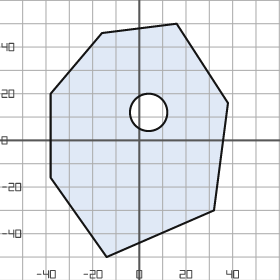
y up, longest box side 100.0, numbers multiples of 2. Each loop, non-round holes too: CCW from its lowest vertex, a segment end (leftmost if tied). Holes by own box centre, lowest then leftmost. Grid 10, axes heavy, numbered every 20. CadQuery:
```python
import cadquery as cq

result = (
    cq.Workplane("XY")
    .moveTo(-14.0, -50.0)
    .lineTo(32.0, -30.0)
    .lineTo(38.0, 16.0)
    .lineTo(16.0, 50.0)
    .lineTo(-16.0, 46.0)
    .lineTo(-38.0, 20.0)
    .lineTo(-38.0, -16.0)
    .close()
    .moveTo(4.0, 12.0)
    .circle(8.0)
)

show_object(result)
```